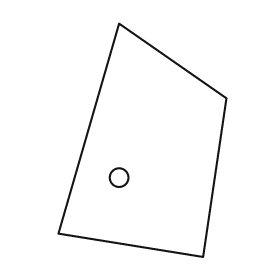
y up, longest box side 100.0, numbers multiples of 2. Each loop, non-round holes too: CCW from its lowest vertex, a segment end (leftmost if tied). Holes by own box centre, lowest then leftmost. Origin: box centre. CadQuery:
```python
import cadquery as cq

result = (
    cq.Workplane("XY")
    .moveTo(26.0, -50.0)
    .lineTo(36.0, 18.0)
    .lineTo(-10.0, 50.0)
    .lineTo(-36.0, -40.0)
    .close()
    .moveTo(-10.0, -16.0)
    .circle(4.0)
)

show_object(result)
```